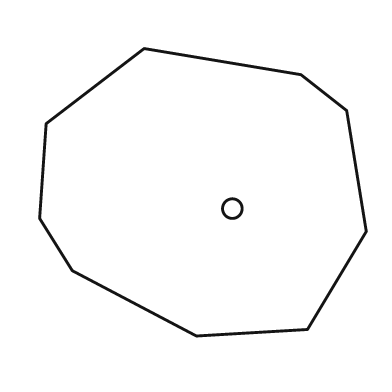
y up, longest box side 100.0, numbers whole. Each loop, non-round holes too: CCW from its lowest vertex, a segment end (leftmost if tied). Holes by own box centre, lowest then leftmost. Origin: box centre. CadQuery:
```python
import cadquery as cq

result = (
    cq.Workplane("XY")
    .moveTo(-2.0, -44.0)
    .lineTo(32.0, -42.0)
    .lineTo(50.0, -12.0)
    .lineTo(44.0, 25.0)
    .lineTo(30.0, 36.0)
    .lineTo(-18.0, 44.0)
    .lineTo(-48.0, 21.0)
    .lineTo(-50.0, -8.0)
    .lineTo(-40.0, -24.0)
    .close()
    .moveTo(9.0, -5.0)
    .circle(3.0)
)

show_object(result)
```